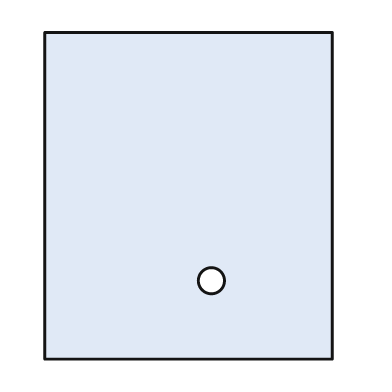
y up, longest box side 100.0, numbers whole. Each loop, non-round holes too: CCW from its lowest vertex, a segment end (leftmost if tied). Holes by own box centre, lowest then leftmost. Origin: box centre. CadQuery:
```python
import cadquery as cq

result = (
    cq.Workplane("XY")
    .moveTo(-44.0, -50.0)
    .lineTo(44.0, -50.0)
    .lineTo(44.0, 50.0)
    .lineTo(-44.0, 50.0)
    .close()
    .moveTo(7.0, -26.0)
    .circle(4.0)
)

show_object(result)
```